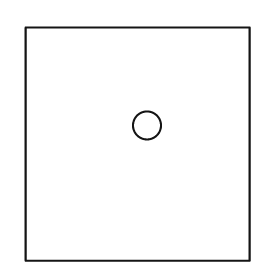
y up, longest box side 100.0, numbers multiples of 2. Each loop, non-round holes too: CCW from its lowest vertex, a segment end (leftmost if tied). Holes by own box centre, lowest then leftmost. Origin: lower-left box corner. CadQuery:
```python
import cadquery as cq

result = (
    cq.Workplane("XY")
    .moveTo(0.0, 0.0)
    .lineTo(96.0, 0.0)
    .lineTo(96.0, 100.0)
    .lineTo(0.0, 100.0)
    .close()
    .moveTo(52.0, 58.0)
    .circle(6.0)
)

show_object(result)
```